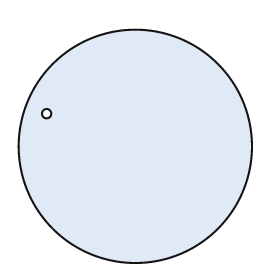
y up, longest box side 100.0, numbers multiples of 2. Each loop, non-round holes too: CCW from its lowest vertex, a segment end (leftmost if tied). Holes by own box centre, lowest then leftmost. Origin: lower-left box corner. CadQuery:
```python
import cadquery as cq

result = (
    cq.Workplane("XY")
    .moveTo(50.0, 50.0)
    .circle(50.0)
    .moveTo(12.0, 64.0)
    .circle(2.0)
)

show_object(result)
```